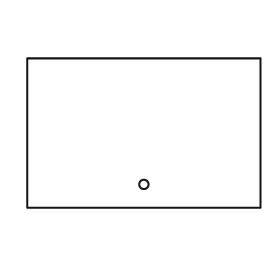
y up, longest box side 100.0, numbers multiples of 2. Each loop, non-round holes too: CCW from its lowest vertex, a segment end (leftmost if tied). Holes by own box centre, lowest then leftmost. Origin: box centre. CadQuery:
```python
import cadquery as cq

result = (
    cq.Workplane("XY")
    .moveTo(-50.0, -32.0)
    .lineTo(50.0, -32.0)
    .lineTo(50.0, 32.0)
    .lineTo(-50.0, 32.0)
    .close()
    .moveTo(0.0, -22.0)
    .circle(2.0)
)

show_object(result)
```